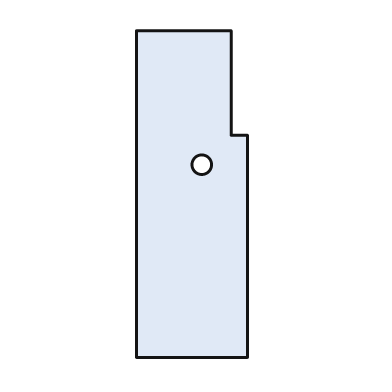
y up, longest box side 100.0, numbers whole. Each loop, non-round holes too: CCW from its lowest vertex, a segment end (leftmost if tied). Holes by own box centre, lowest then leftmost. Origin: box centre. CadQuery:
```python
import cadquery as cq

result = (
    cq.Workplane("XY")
    .moveTo(-17.0, -50.0)
    .lineTo(17.0, -50.0)
    .lineTo(17.0, 18.0)
    .lineTo(12.0, 18.0)
    .lineTo(12.0, 50.0)
    .lineTo(-17.0, 50.0)
    .close()
    .moveTo(3.0, 9.0)
    .circle(3.0)
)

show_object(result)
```